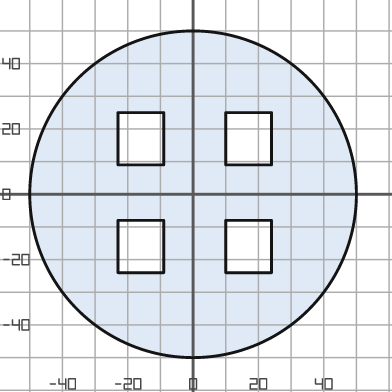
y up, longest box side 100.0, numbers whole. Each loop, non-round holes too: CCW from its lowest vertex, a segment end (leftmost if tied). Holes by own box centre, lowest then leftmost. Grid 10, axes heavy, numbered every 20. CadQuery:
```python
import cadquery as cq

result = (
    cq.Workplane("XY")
    .moveTo(0.0, 0.0)
    .circle(50.0)
    .moveTo(-23.0, -24.0)
    .lineTo(-9.0, -24.0)
    .lineTo(-9.0, -8.0)
    .lineTo(-23.0, -8.0)
    .close()
    .moveTo(10.0, -24.0)
    .lineTo(24.0, -24.0)
    .lineTo(24.0, -8.0)
    .lineTo(10.0, -8.0)
    .close()
    .moveTo(-23.0, 9.0)
    .lineTo(-9.0, 9.0)
    .lineTo(-9.0, 25.0)
    .lineTo(-23.0, 25.0)
    .close()
    .moveTo(10.0, 9.0)
    .lineTo(24.0, 9.0)
    .lineTo(24.0, 25.0)
    .lineTo(10.0, 25.0)
    .close()
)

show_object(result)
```